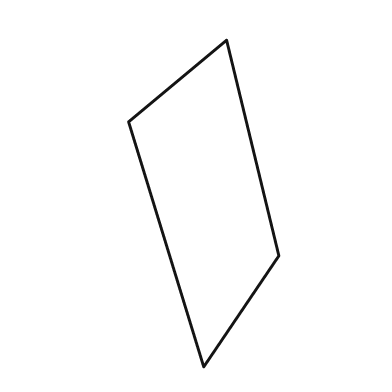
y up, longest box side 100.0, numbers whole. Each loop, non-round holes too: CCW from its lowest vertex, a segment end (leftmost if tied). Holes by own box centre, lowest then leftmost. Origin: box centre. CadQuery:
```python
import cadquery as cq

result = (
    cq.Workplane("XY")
    .moveTo(0.0, -50.0)
    .lineTo(23.0, -16.0)
    .lineTo(7.0, 50.0)
    .lineTo(-23.0, 25.0)
    .close()
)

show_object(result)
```